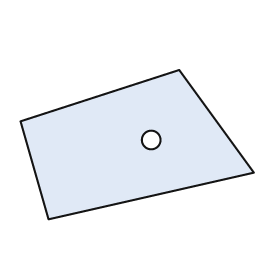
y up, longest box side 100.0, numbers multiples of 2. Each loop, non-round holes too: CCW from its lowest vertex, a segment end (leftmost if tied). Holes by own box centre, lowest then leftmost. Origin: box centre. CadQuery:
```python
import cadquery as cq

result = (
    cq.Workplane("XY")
    .moveTo(-38.0, -32.0)
    .lineTo(50.0, -12.0)
    .lineTo(18.0, 32.0)
    .lineTo(-50.0, 10.0)
    .close()
    .moveTo(6.0, 2.0)
    .circle(4.0)
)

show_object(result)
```